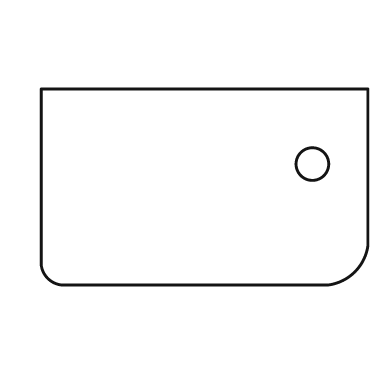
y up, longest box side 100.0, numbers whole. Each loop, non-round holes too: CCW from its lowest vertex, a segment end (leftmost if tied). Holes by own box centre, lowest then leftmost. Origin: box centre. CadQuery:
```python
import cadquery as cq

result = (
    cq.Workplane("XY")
    .moveTo(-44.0, -30.0)
    .lineTo(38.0, -30.0)
    .threePointArc((46.0, -26.0), (50.0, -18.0))
    .lineTo(50.0, 30.0)
    .lineTo(-50.0, 30.0)
    .lineTo(-50.0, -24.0)
    .threePointArc((-48.0, -28.0), (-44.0, -30.0))
    .close()
    .moveTo(33.0, 7.0)
    .circle(5.0)
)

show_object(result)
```